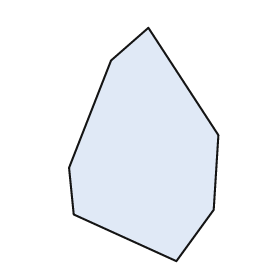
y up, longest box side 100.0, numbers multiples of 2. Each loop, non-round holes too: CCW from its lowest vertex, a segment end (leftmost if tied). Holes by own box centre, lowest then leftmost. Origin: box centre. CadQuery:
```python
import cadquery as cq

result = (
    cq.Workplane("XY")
    .moveTo(14.0, -50.0)
    .lineTo(30.0, -28.0)
    .lineTo(32.0, 4.0)
    .lineTo(2.0, 50.0)
    .lineTo(-14.0, 36.0)
    .lineTo(-32.0, -10.0)
    .lineTo(-30.0, -30.0)
    .close()
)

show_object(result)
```